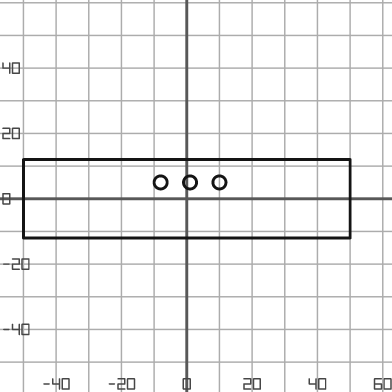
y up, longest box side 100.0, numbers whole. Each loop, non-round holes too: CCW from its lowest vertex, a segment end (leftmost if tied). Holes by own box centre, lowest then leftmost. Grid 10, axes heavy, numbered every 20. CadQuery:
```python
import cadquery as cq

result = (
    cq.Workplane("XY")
    .moveTo(-50.0, -12.0)
    .lineTo(50.0, -12.0)
    .lineTo(50.0, 12.0)
    .lineTo(-50.0, 12.0)
    .close()
    .moveTo(-8.0, 5.0)
    .circle(2.0)
    .moveTo(1.0, 5.0)
    .circle(2.0)
    .moveTo(10.0, 5.0)
    .circle(2.0)
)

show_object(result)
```